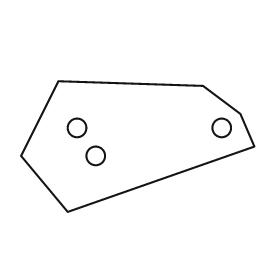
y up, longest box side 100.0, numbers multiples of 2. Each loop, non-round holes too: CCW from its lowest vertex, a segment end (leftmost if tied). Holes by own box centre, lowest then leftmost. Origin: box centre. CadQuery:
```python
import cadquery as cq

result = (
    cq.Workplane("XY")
    .moveTo(-30.0, -28.0)
    .lineTo(50.0, 0.0)
    .lineTo(44.0, 14.0)
    .lineTo(28.0, 26.0)
    .lineTo(-34.0, 28.0)
    .lineTo(-50.0, -4.0)
    .close()
    .moveTo(-18.0, -4.0)
    .circle(4.0)
    .moveTo(-26.0, 8.0)
    .circle(4.0)
    .moveTo(36.0, 8.0)
    .circle(4.0)
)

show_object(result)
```